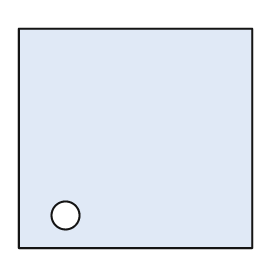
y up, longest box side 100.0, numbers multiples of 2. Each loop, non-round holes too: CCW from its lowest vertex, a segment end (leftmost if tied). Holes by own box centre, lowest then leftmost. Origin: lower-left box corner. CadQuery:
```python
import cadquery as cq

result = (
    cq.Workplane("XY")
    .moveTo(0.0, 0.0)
    .lineTo(100.0, 0.0)
    .lineTo(100.0, 94.0)
    .lineTo(0.0, 94.0)
    .close()
    .moveTo(20.0, 14.0)
    .circle(6.0)
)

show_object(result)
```